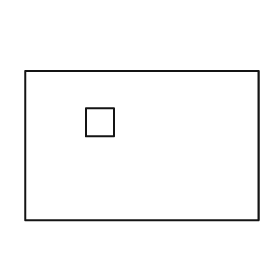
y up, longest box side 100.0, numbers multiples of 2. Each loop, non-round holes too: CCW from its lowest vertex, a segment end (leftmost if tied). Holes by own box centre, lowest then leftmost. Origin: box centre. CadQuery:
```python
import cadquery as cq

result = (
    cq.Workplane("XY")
    .moveTo(-50.0, -32.0)
    .lineTo(50.0, -32.0)
    .lineTo(50.0, 32.0)
    .lineTo(-50.0, 32.0)
    .close()
    .moveTo(-24.0, 4.0)
    .lineTo(-12.0, 4.0)
    .lineTo(-12.0, 16.0)
    .lineTo(-24.0, 16.0)
    .close()
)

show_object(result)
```